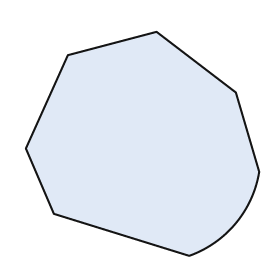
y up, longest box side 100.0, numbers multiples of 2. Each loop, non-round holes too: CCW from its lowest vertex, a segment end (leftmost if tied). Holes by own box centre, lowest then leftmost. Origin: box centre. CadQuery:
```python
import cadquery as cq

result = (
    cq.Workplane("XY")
    .moveTo(20.0, -48.0)
    .threePointArc((40.0, -34.0), (50.0, -12.0))
    .lineTo(40.0, 22.0)
    .lineTo(6.0, 48.0)
    .lineTo(-32.0, 38.0)
    .lineTo(-50.0, -2.0)
    .lineTo(-38.0, -30.0)
    .close()
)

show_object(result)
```